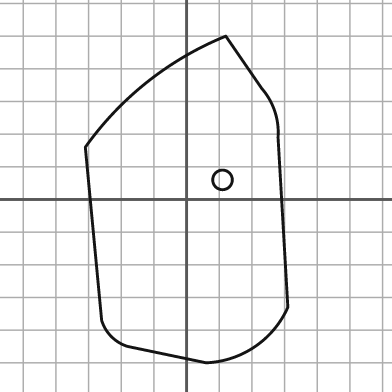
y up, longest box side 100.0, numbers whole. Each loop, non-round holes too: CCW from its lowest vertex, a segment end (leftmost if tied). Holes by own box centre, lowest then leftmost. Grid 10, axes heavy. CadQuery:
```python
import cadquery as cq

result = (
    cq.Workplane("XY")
    .moveTo(6.0, -50.0)
    .threePointArc((21.0, -45.0), (31.0, -33.0))
    .lineTo(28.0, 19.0)
    .threePointArc((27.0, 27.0), (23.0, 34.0))
    .lineTo(12.0, 50.0)
    .threePointArc((-12.0, 36.0), (-31.0, 16.0))
    .lineTo(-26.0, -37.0)
    .threePointArc((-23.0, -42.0), (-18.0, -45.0))
    .close()
    .moveTo(11.0, 6.0)
    .circle(3.0)
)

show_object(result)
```